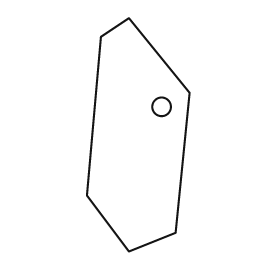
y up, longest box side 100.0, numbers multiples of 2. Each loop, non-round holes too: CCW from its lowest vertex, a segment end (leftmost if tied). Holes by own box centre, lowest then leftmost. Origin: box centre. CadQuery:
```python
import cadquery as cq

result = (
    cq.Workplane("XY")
    .moveTo(-4.0, -50.0)
    .lineTo(16.0, -42.0)
    .lineTo(22.0, 18.0)
    .lineTo(-4.0, 50.0)
    .lineTo(-16.0, 42.0)
    .lineTo(-22.0, -26.0)
    .close()
    .moveTo(10.0, 12.0)
    .circle(4.0)
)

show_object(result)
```